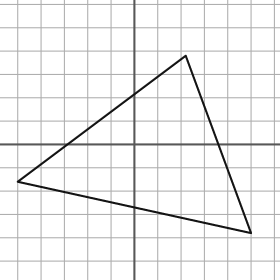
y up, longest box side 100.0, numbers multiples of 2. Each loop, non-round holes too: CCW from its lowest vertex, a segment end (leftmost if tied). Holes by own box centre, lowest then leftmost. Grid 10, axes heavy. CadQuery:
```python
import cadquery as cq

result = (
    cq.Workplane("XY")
    .moveTo(50.0, -38.0)
    .lineTo(22.0, 38.0)
    .lineTo(-50.0, -16.0)
    .close()
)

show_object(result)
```